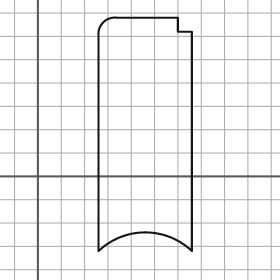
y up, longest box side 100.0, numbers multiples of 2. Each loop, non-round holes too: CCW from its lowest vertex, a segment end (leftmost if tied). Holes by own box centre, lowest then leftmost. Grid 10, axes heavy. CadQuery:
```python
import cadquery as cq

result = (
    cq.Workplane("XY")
    .moveTo(26.0, -32.0)
    .threePointArc((46.0, -24.0), (66.0, -32.0))
    .lineTo(66.0, 62.0)
    .lineTo(60.0, 62.0)
    .lineTo(60.0, 68.0)
    .lineTo(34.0, 68.0)
    .threePointArc((28.0, 66.0), (26.0, 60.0))
    .close()
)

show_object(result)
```